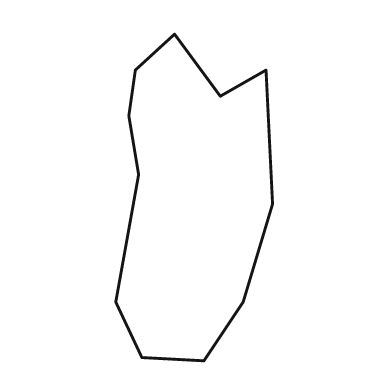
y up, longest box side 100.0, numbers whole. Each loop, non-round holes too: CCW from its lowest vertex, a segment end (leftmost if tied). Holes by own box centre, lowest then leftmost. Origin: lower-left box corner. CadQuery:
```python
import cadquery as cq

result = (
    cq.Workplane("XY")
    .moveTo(27.0, 0.0)
    .lineTo(39.0, 18.0)
    .lineTo(48.0, 48.0)
    .lineTo(46.0, 89.0)
    .lineTo(32.0, 81.0)
    .lineTo(18.0, 100.0)
    .lineTo(6.0, 89.0)
    .lineTo(4.0, 75.0)
    .lineTo(7.0, 57.0)
    .lineTo(0.0, 18.0)
    .lineTo(8.0, 1.0)
    .close()
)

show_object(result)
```